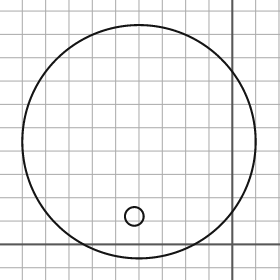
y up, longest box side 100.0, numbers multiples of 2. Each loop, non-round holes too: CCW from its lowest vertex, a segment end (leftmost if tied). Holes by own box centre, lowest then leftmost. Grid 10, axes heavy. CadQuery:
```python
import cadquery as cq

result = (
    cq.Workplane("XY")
    .moveTo(-40.0, 44.0)
    .circle(50.0)
    .moveTo(-42.0, 12.0)
    .circle(4.0)
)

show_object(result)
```